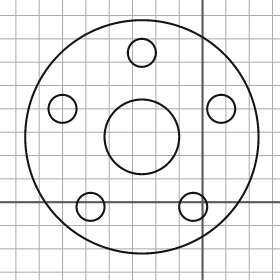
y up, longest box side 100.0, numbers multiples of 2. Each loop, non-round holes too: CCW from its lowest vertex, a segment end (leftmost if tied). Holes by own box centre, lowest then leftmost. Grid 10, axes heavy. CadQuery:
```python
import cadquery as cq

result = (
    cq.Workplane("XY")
    .moveTo(-26.0, 28.0)
    .circle(50.0)
    .moveTo(-48.0, -2.0)
    .circle(6.0)
    .moveTo(-4.0, -2.0)
    .circle(6.0)
    .moveTo(-26.0, 28.0)
    .circle(16.0)
    .moveTo(-60.0, 40.0)
    .circle(6.0)
    .moveTo(8.0, 40.0)
    .circle(6.0)
    .moveTo(-26.0, 64.0)
    .circle(6.0)
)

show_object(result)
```